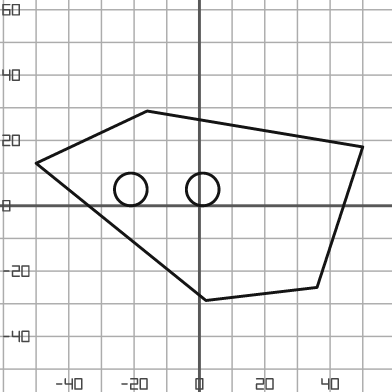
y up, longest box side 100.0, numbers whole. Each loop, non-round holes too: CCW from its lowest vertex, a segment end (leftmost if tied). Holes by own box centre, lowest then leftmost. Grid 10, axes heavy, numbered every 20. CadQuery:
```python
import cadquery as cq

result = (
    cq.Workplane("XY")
    .moveTo(2.0, -29.0)
    .lineTo(36.0, -25.0)
    .lineTo(50.0, 18.0)
    .lineTo(-16.0, 29.0)
    .lineTo(-50.0, 13.0)
    .close()
    .moveTo(-21.0, 5.0)
    .circle(5.0)
    .moveTo(1.0, 5.0)
    .circle(5.0)
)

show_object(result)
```